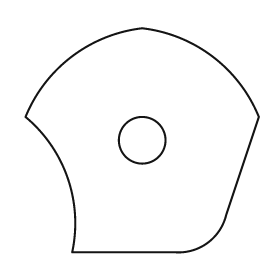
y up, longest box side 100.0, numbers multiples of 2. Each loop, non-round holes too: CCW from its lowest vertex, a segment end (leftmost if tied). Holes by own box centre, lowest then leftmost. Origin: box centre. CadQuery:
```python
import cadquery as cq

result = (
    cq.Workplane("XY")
    .moveTo(-30.0, -48.0)
    .lineTo(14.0, -48.0)
    .threePointArc((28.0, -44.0), (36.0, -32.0))
    .lineTo(50.0, 10.0)
    .threePointArc((30.0, 36.0), (0.0, 48.0))
    .threePointArc((-30.0, 36.0), (-50.0, 10.0))
    .threePointArc((-32.0, -16.0), (-30.0, -48.0))
    .close()
    .moveTo(0.0, 0.0)
    .circle(10.0)
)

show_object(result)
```